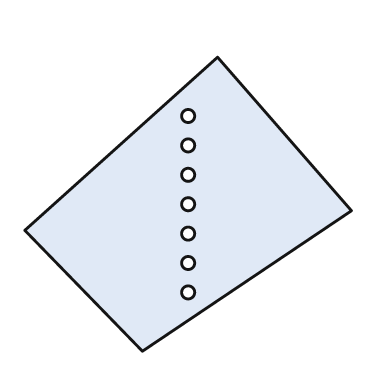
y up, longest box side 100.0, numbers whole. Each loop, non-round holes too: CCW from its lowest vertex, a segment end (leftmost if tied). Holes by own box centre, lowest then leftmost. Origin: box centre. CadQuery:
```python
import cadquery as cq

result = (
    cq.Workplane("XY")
    .moveTo(-14.0, -45.0)
    .lineTo(50.0, -2.0)
    .lineTo(9.0, 45.0)
    .lineTo(-50.0, -8.0)
    .close()
    .moveTo(0.0, -27.0)
    .circle(2.0)
    .moveTo(0.0, -18.0)
    .circle(2.0)
    .moveTo(0.0, -9.0)
    .circle(2.0)
    .moveTo(0.0, 0.0)
    .circle(2.0)
    .moveTo(0.0, 9.0)
    .circle(2.0)
    .moveTo(0.0, 18.0)
    .circle(2.0)
    .moveTo(0.0, 27.0)
    .circle(2.0)
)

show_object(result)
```